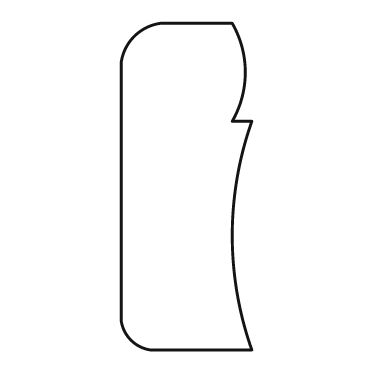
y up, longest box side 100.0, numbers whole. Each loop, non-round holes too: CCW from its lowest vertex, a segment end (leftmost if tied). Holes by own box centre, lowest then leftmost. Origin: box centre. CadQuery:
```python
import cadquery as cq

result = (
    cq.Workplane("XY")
    .moveTo(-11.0, -50.0)
    .lineTo(20.0, -50.0)
    .threePointArc((14.0, -15.0), (20.0, 20.0))
    .lineTo(14.0, 20.0)
    .threePointArc((18.0, 35.0), (14.0, 50.0))
    .lineTo(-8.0, 50.0)
    .threePointArc((-16.0, 46.0), (-20.0, 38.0))
    .lineTo(-20.0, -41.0)
    .threePointArc((-17.0, -47.0), (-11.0, -50.0))
    .close()
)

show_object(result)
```